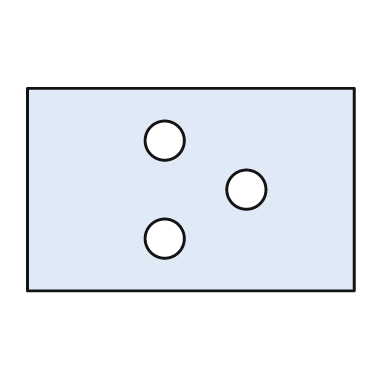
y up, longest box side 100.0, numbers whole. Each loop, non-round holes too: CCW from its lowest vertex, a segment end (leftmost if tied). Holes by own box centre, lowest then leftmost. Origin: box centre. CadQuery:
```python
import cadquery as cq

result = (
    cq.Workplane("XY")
    .moveTo(-50.0, -31.0)
    .lineTo(50.0, -31.0)
    .lineTo(50.0, 31.0)
    .lineTo(-50.0, 31.0)
    .close()
    .moveTo(-8.0, -15.0)
    .circle(6.0)
    .moveTo(17.0, 0.0)
    .circle(6.0)
    .moveTo(-8.0, 15.0)
    .circle(6.0)
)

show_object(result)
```